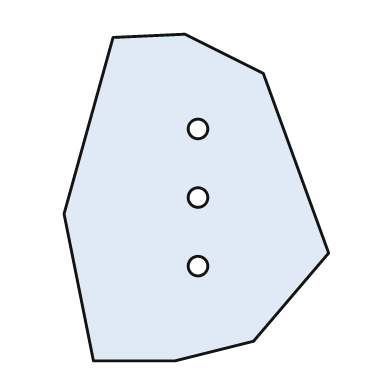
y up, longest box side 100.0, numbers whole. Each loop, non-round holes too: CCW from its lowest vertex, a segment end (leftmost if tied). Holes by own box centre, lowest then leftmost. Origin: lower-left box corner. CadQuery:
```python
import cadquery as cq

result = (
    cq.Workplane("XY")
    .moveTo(9.0, 0.0)
    .lineTo(34.0, 0.0)
    .lineTo(58.0, 6.0)
    .lineTo(81.0, 33.0)
    .lineTo(61.0, 88.0)
    .lineTo(37.0, 100.0)
    .lineTo(15.0, 99.0)
    .lineTo(0.0, 45.0)
    .close()
    .moveTo(41.0, 29.0)
    .circle(3.0)
    .moveTo(41.0, 50.0)
    .circle(3.0)
    .moveTo(41.0, 71.0)
    .circle(3.0)
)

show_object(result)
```